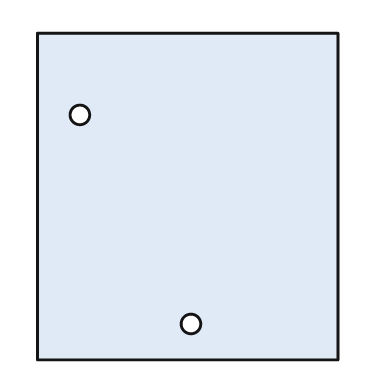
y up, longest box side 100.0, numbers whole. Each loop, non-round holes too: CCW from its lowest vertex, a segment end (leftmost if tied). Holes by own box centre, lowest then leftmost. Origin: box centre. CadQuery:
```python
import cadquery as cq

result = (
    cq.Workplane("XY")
    .moveTo(-46.0, -50.0)
    .lineTo(46.0, -50.0)
    .lineTo(46.0, 50.0)
    .lineTo(-46.0, 50.0)
    .close()
    .moveTo(1.0, -39.0)
    .circle(3.0)
    .moveTo(-33.0, 25.0)
    .circle(3.0)
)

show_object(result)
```